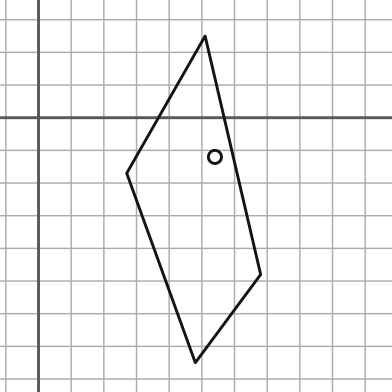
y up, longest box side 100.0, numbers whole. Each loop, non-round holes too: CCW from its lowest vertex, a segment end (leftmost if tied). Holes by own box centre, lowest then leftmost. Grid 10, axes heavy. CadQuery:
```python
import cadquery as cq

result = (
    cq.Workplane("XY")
    .moveTo(48.0, -75.0)
    .lineTo(68.0, -48.0)
    .lineTo(51.0, 25.0)
    .lineTo(27.0, -17.0)
    .close()
    .moveTo(54.0, -12.0)
    .circle(2.0)
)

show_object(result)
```